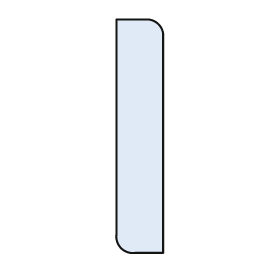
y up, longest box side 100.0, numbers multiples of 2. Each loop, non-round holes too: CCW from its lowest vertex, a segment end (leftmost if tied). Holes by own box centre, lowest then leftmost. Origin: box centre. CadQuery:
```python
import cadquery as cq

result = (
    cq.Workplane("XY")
    .moveTo(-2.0, -50.0)
    .lineTo(10.0, -50.0)
    .lineTo(10.0, 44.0)
    .threePointArc((8.0, 48.0), (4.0, 50.0))
    .lineTo(-10.0, 50.0)
    .lineTo(-10.0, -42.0)
    .threePointArc((-8.0, -48.0), (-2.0, -50.0))
    .close()
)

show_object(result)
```